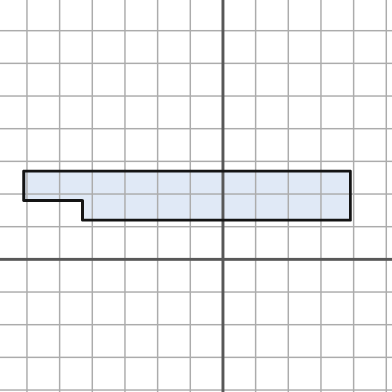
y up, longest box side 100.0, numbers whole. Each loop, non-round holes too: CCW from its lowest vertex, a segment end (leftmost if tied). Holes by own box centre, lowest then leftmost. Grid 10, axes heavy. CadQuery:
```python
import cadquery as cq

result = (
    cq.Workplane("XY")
    .moveTo(-43.0, 12.0)
    .lineTo(39.0, 12.0)
    .lineTo(39.0, 27.0)
    .lineTo(-61.0, 27.0)
    .lineTo(-61.0, 18.0)
    .lineTo(-43.0, 18.0)
    .close()
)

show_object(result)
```